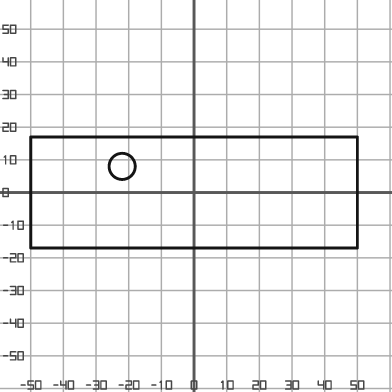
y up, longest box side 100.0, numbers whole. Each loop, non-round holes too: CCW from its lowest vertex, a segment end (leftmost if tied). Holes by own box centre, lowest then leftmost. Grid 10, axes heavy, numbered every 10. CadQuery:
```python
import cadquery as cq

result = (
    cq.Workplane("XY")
    .moveTo(-50.0, -17.0)
    .lineTo(50.0, -17.0)
    .lineTo(50.0, 17.0)
    .lineTo(-50.0, 17.0)
    .close()
    .moveTo(-22.0, 8.0)
    .circle(4.0)
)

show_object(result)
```